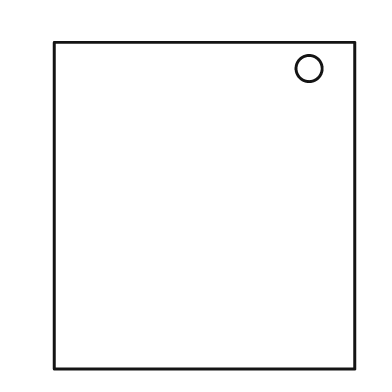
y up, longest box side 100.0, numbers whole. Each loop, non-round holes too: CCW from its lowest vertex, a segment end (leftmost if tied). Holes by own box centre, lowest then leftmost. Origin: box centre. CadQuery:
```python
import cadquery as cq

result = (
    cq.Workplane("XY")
    .moveTo(-46.0, -50.0)
    .lineTo(46.0, -50.0)
    .lineTo(46.0, 50.0)
    .lineTo(-46.0, 50.0)
    .close()
    .moveTo(32.0, 42.0)
    .circle(4.0)
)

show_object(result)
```